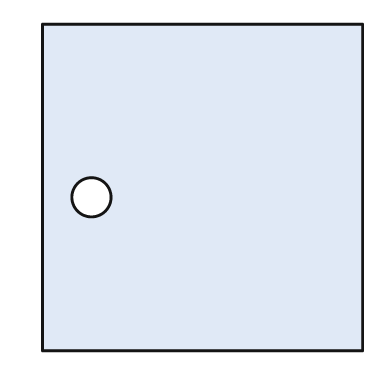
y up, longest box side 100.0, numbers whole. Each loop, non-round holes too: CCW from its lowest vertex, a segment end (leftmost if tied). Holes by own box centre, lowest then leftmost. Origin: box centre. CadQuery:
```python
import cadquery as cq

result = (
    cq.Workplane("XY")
    .moveTo(-49.0, -50.0)
    .lineTo(49.0, -50.0)
    .lineTo(49.0, 50.0)
    .lineTo(-49.0, 50.0)
    .close()
    .moveTo(-34.0, -3.0)
    .circle(6.0)
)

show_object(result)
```